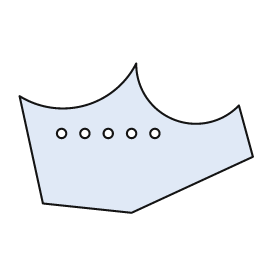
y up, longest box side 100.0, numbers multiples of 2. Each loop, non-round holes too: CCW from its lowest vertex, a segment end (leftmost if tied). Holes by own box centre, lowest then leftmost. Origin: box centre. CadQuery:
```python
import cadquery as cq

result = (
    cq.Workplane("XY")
    .moveTo(-2.0, -32.0)
    .lineTo(50.0, -8.0)
    .lineTo(44.0, 14.0)
    .threePointArc((16.0, 8.0), (0.0, 32.0))
    .threePointArc((-22.0, 14.0), (-50.0, 18.0))
    .lineTo(-40.0, -28.0)
    .close()
    .moveTo(-32.0, 2.0)
    .circle(2.0)
    .moveTo(-22.0, 2.0)
    .circle(2.0)
    .moveTo(-12.0, 2.0)
    .circle(2.0)
    .moveTo(-2.0, 2.0)
    .circle(2.0)
    .moveTo(8.0, 2.0)
    .circle(2.0)
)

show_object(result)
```